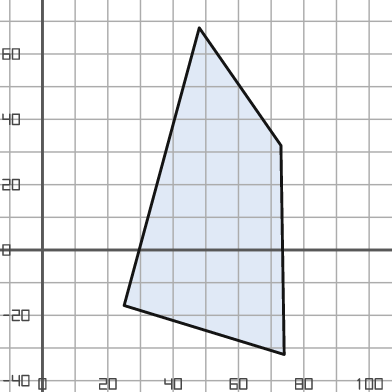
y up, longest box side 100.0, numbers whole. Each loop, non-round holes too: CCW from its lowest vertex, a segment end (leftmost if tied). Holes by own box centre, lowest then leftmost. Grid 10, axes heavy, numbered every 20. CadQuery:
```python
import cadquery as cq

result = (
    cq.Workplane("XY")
    .moveTo(74.0, -32.0)
    .lineTo(73.0, 32.0)
    .lineTo(48.0, 68.0)
    .lineTo(25.0, -17.0)
    .close()
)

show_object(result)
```